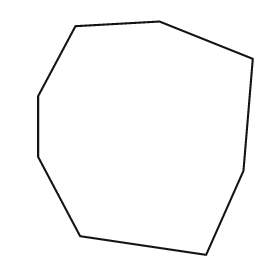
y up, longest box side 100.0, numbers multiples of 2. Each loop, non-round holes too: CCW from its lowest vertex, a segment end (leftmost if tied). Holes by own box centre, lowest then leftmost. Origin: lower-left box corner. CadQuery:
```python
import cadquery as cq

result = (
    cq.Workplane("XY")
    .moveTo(72.0, 0.0)
    .lineTo(88.0, 36.0)
    .lineTo(92.0, 84.0)
    .lineTo(52.0, 100.0)
    .lineTo(16.0, 98.0)
    .lineTo(0.0, 68.0)
    .lineTo(0.0, 42.0)
    .lineTo(18.0, 8.0)
    .close()
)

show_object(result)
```